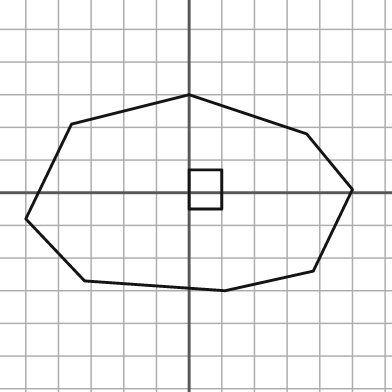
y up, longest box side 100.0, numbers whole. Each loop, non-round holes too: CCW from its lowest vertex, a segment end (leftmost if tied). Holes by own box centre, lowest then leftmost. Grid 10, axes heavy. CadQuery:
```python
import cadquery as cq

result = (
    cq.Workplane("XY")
    .moveTo(11.0, -30.0)
    .lineTo(38.0, -24.0)
    .lineTo(50.0, 1.0)
    .lineTo(36.0, 18.0)
    .lineTo(0.0, 30.0)
    .lineTo(-36.0, 21.0)
    .lineTo(-50.0, -8.0)
    .lineTo(-32.0, -27.0)
    .close()
    .moveTo(0.0, -5.0)
    .lineTo(10.0, -5.0)
    .lineTo(10.0, 7.0)
    .lineTo(0.0, 7.0)
    .close()
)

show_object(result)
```